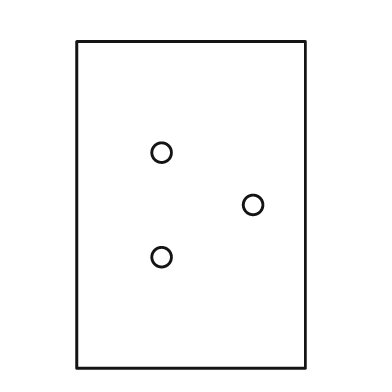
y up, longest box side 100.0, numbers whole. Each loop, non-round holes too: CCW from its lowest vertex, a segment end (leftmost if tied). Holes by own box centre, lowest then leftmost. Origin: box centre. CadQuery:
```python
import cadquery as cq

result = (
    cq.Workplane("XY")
    .moveTo(-35.0, -50.0)
    .lineTo(35.0, -50.0)
    .lineTo(35.0, 50.0)
    .lineTo(-35.0, 50.0)
    .close()
    .moveTo(-9.0, -16.0)
    .circle(3.0)
    .moveTo(19.0, 0.0)
    .circle(3.0)
    .moveTo(-9.0, 16.0)
    .circle(3.0)
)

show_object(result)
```